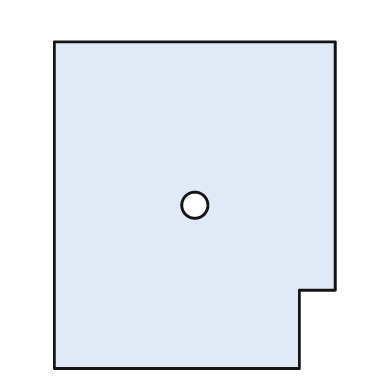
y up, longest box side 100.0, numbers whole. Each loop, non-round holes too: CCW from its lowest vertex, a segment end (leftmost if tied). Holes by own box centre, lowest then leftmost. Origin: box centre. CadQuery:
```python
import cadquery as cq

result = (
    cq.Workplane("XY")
    .moveTo(-43.0, -50.0)
    .lineTo(32.0, -50.0)
    .lineTo(32.0, -26.0)
    .lineTo(43.0, -26.0)
    .lineTo(43.0, 50.0)
    .lineTo(-43.0, 50.0)
    .close()
    .moveTo(0.0, 0.0)
    .circle(4.0)
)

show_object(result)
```